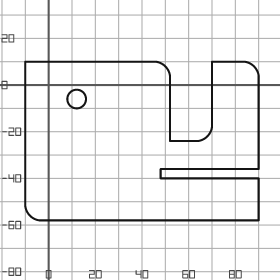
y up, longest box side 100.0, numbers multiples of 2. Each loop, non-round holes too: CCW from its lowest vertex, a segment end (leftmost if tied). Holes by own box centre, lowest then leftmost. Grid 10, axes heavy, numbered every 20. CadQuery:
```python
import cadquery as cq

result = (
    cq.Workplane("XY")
    .moveTo(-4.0, -58.0)
    .lineTo(90.0, -58.0)
    .lineTo(90.0, -40.0)
    .lineTo(48.0, -40.0)
    .lineTo(48.0, -36.0)
    .lineTo(90.0, -36.0)
    .lineTo(90.0, 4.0)
    .threePointArc((88.0, 8.0), (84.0, 10.0))
    .lineTo(70.0, 10.0)
    .lineTo(70.0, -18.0)
    .threePointArc((68.0, -22.0), (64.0, -24.0))
    .lineTo(52.0, -24.0)
    .lineTo(52.0, 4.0)
    .threePointArc((50.0, 8.0), (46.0, 10.0))
    .lineTo(-10.0, 10.0)
    .lineTo(-10.0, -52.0)
    .threePointArc((-8.0, -56.0), (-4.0, -58.0))
    .close()
    .moveTo(12.0, -6.0)
    .circle(4.0)
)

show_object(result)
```